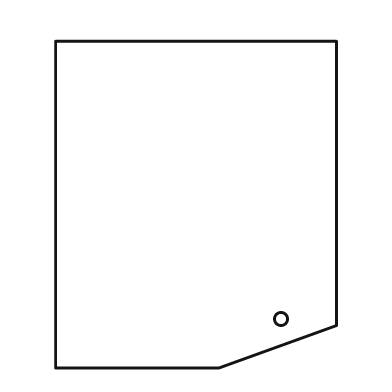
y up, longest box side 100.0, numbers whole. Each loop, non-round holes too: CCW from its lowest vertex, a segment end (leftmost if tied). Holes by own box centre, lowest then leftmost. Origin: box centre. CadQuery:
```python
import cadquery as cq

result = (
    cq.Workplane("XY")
    .moveTo(-43.0, -50.0)
    .lineTo(7.0, -50.0)
    .lineTo(43.0, -37.0)
    .lineTo(43.0, 50.0)
    .lineTo(-43.0, 50.0)
    .close()
    .moveTo(26.0, -35.0)
    .circle(2.0)
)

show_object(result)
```